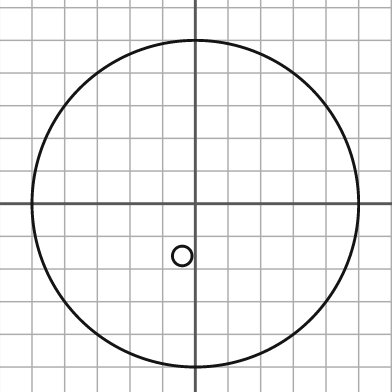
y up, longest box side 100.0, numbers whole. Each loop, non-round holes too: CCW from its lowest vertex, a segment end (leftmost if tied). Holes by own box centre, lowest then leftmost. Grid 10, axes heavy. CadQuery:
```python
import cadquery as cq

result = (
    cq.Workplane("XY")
    .moveTo(0.0, 0.0)
    .circle(50.0)
    .moveTo(-4.0, -16.0)
    .circle(3.0)
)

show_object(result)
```